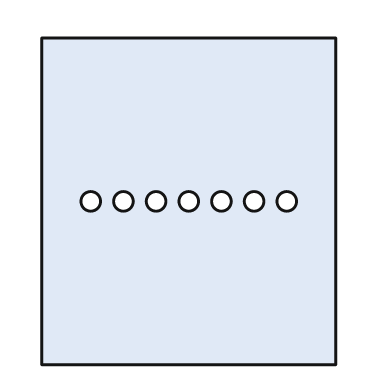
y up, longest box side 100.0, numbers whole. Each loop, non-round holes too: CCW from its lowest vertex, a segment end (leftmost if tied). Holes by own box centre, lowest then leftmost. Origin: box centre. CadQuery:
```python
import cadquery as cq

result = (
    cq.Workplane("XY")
    .moveTo(-45.0, -50.0)
    .lineTo(45.0, -50.0)
    .lineTo(45.0, 50.0)
    .lineTo(-45.0, 50.0)
    .close()
    .moveTo(-30.0, 0.0)
    .circle(3.0)
    .moveTo(-20.0, 0.0)
    .circle(3.0)
    .moveTo(-10.0, 0.0)
    .circle(3.0)
    .moveTo(0.0, 0.0)
    .circle(3.0)
    .moveTo(10.0, 0.0)
    .circle(3.0)
    .moveTo(20.0, 0.0)
    .circle(3.0)
    .moveTo(30.0, 0.0)
    .circle(3.0)
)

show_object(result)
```